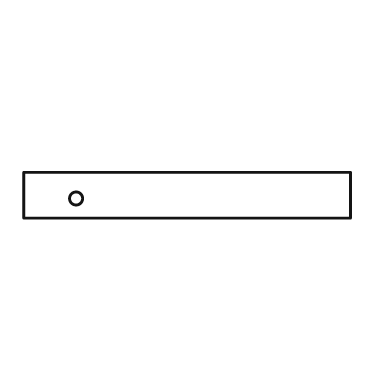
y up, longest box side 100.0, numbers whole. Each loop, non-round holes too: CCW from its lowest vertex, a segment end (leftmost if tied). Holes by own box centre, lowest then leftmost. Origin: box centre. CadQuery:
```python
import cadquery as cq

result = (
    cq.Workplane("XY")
    .moveTo(-50.0, -7.0)
    .lineTo(50.0, -7.0)
    .lineTo(50.0, 7.0)
    .lineTo(-50.0, 7.0)
    .close()
    .moveTo(-34.0, -1.0)
    .circle(2.0)
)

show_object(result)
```